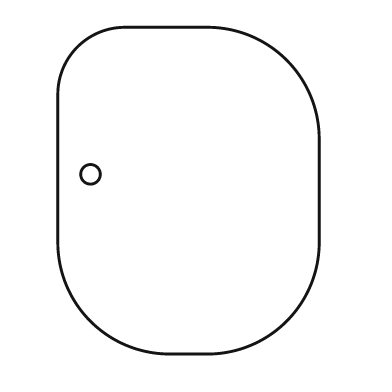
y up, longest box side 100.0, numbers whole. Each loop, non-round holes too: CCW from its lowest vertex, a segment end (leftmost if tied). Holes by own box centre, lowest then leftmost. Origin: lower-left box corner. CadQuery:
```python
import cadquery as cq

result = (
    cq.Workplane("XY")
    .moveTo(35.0, 0.0)
    .lineTo(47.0, 0.0)
    .threePointArc((70.0, 10.0), (80.0, 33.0))
    .lineTo(80.0, 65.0)
    .threePointArc((70.0, 90.0), (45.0, 100.0))
    .lineTo(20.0, 100.0)
    .threePointArc((6.0, 94.0), (0.0, 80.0))
    .lineTo(0.0, 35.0)
    .threePointArc((10.0, 10.0), (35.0, 0.0))
    .close()
    .moveTo(10.0, 55.0)
    .circle(3.0)
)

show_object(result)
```